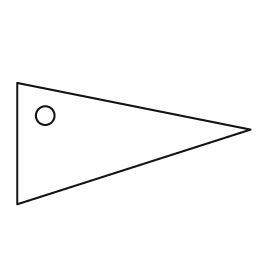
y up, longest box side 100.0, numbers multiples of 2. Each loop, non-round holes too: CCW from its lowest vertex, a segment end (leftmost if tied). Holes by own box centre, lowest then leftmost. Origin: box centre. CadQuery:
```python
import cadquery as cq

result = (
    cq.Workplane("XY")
    .moveTo(-50.0, -26.0)
    .lineTo(50.0, 6.0)
    .lineTo(-50.0, 26.0)
    .close()
    .moveTo(-38.0, 12.0)
    .circle(4.0)
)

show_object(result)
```